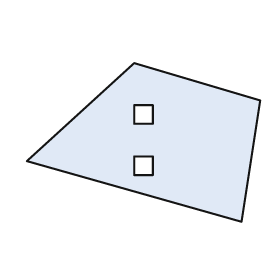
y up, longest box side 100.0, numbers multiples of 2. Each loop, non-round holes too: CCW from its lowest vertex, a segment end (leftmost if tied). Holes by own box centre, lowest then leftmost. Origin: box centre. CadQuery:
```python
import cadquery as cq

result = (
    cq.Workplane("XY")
    .moveTo(42.0, -34.0)
    .lineTo(50.0, 18.0)
    .lineTo(-4.0, 34.0)
    .lineTo(-50.0, -8.0)
    .close()
    .moveTo(-4.0, -14.0)
    .lineTo(4.0, -14.0)
    .lineTo(4.0, -6.0)
    .lineTo(-4.0, -6.0)
    .close()
    .moveTo(-4.0, 8.0)
    .lineTo(4.0, 8.0)
    .lineTo(4.0, 16.0)
    .lineTo(-4.0, 16.0)
    .close()
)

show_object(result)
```